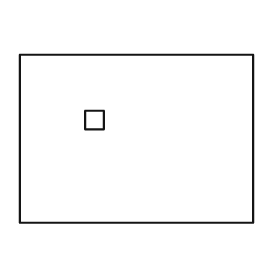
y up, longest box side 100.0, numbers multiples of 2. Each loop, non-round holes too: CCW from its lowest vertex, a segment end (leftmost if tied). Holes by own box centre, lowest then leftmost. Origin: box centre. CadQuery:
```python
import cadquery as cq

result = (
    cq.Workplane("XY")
    .moveTo(-50.0, -36.0)
    .lineTo(50.0, -36.0)
    .lineTo(50.0, 36.0)
    .lineTo(-50.0, 36.0)
    .close()
    .moveTo(-22.0, 4.0)
    .lineTo(-14.0, 4.0)
    .lineTo(-14.0, 12.0)
    .lineTo(-22.0, 12.0)
    .close()
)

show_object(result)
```